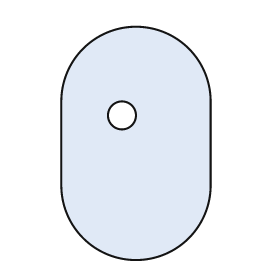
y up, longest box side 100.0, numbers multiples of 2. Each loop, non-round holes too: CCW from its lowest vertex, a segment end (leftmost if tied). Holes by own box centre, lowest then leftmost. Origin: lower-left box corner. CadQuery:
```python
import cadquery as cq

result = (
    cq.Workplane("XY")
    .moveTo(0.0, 32.0)
    .threePointArc((32.0, 0.0), (64.0, 32.0))
    .lineTo(64.0, 68.0)
    .threePointArc((32.0, 100.0), (0.0, 68.0))
    .close()
    .moveTo(26.0, 62.0)
    .circle(6.0)
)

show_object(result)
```